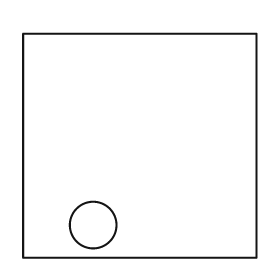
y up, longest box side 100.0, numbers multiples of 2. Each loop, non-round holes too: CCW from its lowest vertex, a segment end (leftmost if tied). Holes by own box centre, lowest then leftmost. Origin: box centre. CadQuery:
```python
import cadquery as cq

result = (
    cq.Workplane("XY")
    .moveTo(-50.0, -48.0)
    .lineTo(50.0, -48.0)
    .lineTo(50.0, 48.0)
    .lineTo(-50.0, 48.0)
    .close()
    .moveTo(-20.0, -34.0)
    .circle(10.0)
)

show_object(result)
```